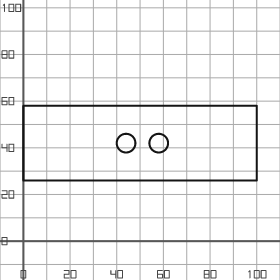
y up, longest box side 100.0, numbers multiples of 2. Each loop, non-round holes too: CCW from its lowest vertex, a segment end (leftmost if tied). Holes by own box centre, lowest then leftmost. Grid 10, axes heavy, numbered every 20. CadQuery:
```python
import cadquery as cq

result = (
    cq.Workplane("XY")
    .moveTo(0.0, 26.0)
    .lineTo(100.0, 26.0)
    .lineTo(100.0, 58.0)
    .lineTo(0.0, 58.0)
    .close()
    .moveTo(44.0, 42.0)
    .circle(4.0)
    .moveTo(58.0, 42.0)
    .circle(4.0)
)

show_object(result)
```